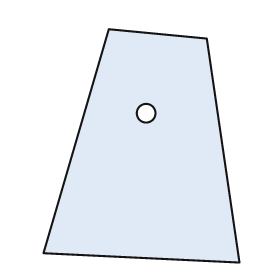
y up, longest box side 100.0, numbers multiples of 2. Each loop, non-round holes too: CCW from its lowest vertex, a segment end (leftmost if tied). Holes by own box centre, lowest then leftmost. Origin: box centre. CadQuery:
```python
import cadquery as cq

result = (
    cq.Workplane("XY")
    .moveTo(42.0, -50.0)
    .lineTo(28.0, 46.0)
    .lineTo(-14.0, 50.0)
    .lineTo(-42.0, -46.0)
    .close()
    .moveTo(2.0, 14.0)
    .circle(4.0)
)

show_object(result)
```